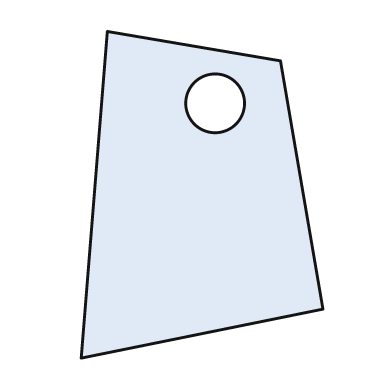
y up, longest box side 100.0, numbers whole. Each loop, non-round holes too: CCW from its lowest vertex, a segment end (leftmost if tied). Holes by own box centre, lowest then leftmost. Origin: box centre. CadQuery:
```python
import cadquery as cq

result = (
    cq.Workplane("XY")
    .moveTo(-37.0, -50.0)
    .lineTo(37.0, -35.0)
    .lineTo(24.0, 41.0)
    .lineTo(-29.0, 50.0)
    .close()
    .moveTo(4.0, 28.0)
    .circle(9.0)
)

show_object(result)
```